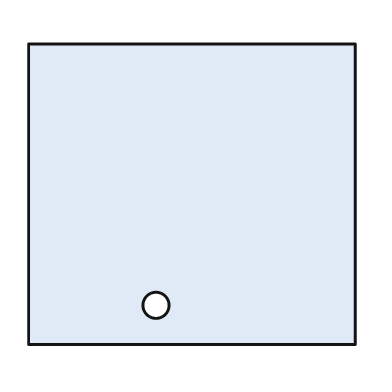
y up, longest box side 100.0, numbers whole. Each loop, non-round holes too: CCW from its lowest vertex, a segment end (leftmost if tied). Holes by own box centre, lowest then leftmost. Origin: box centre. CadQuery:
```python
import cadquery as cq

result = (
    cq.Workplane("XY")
    .moveTo(-50.0, -46.0)
    .lineTo(50.0, -46.0)
    .lineTo(50.0, 46.0)
    .lineTo(-50.0, 46.0)
    .close()
    .moveTo(-11.0, -34.0)
    .circle(4.0)
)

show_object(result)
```